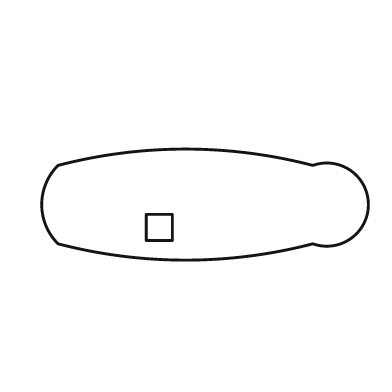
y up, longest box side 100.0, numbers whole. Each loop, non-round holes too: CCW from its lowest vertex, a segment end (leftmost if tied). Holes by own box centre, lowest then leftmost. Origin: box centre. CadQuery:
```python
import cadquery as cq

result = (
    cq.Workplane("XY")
    .moveTo(-45.0, -12.0)
    .threePointArc((-6.0, -17.0), (33.0, -12.0))
    .threePointArc((50.0, 0.0), (33.0, 12.0))
    .threePointArc((-6.0, 17.0), (-45.0, 12.0))
    .threePointArc((-50.0, 0.0), (-45.0, -12.0))
    .close()
    .moveTo(-18.0, -11.0)
    .lineTo(-10.0, -11.0)
    .lineTo(-10.0, -3.0)
    .lineTo(-18.0, -3.0)
    .close()
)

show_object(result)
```